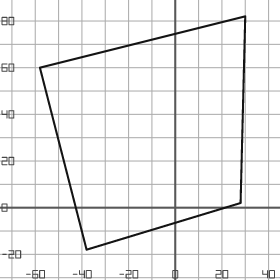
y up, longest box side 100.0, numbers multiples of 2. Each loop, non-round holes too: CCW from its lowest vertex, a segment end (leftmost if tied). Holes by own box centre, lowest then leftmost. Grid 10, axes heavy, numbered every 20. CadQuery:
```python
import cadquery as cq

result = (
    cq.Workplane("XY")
    .moveTo(-38.0, -18.0)
    .lineTo(28.0, 2.0)
    .lineTo(30.0, 82.0)
    .lineTo(-58.0, 60.0)
    .close()
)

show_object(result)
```